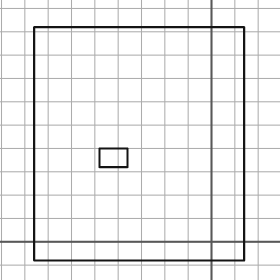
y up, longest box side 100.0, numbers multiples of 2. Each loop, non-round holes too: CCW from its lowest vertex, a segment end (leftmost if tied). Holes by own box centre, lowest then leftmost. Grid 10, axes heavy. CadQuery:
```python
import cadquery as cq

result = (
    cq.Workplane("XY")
    .moveTo(-76.0, -8.0)
    .lineTo(14.0, -8.0)
    .lineTo(14.0, 92.0)
    .lineTo(-76.0, 92.0)
    .close()
    .moveTo(-48.0, 32.0)
    .lineTo(-36.0, 32.0)
    .lineTo(-36.0, 40.0)
    .lineTo(-48.0, 40.0)
    .close()
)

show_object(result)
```